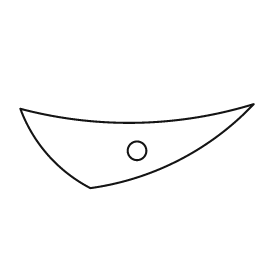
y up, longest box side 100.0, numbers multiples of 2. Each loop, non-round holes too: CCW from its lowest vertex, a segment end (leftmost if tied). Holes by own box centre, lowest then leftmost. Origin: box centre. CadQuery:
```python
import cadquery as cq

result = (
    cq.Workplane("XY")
    .moveTo(-20.0, -18.0)
    .threePointArc((18.0, -6.0), (50.0, 18.0))
    .threePointArc((0.0, 10.0), (-50.0, 16.0))
    .threePointArc((-38.0, -4.0), (-20.0, -18.0))
    .close()
    .moveTo(0.0, -2.0)
    .circle(4.0)
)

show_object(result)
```